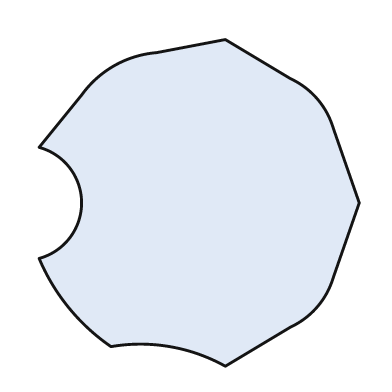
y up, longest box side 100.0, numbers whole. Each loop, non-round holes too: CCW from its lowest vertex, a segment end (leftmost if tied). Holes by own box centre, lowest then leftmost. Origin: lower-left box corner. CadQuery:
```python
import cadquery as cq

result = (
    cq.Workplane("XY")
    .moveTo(57.0, 0.0)
    .lineTo(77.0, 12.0)
    .threePointArc((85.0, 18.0), (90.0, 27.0))
    .lineTo(98.0, 50.0)
    .lineTo(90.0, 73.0)
    .threePointArc((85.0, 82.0), (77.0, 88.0))
    .lineTo(57.0, 100.0)
    .lineTo(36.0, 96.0)
    .threePointArc((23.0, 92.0), (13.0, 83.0))
    .lineTo(0.0, 67.0)
    .threePointArc((13.0, 50.0), (0.0, 33.0))
    .threePointArc((9.0, 18.0), (22.0, 6.0))
    .threePointArc((40.0, 6.0), (57.0, 0.0))
    .close()
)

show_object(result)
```